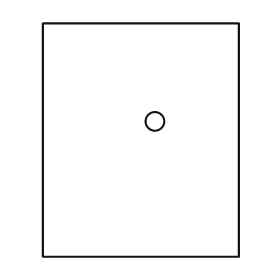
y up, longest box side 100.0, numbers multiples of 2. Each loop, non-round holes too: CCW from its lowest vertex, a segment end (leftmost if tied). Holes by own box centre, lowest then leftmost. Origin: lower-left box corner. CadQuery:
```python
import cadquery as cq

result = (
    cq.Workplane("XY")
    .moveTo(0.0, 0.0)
    .lineTo(84.0, 0.0)
    .lineTo(84.0, 100.0)
    .lineTo(0.0, 100.0)
    .close()
    .moveTo(48.0, 58.0)
    .circle(4.0)
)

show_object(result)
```